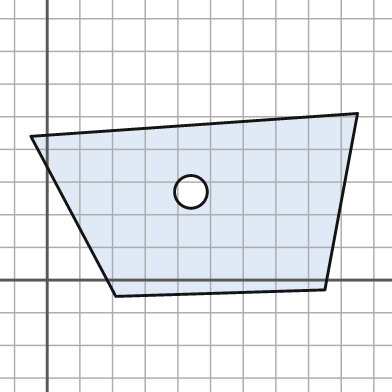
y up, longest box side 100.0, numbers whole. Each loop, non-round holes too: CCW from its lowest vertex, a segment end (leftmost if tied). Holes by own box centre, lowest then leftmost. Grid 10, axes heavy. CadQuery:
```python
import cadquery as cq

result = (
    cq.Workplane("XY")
    .moveTo(21.0, -5.0)
    .lineTo(85.0, -3.0)
    .lineTo(95.0, 51.0)
    .lineTo(-5.0, 44.0)
    .close()
    .moveTo(44.0, 27.0)
    .circle(5.0)
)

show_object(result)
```